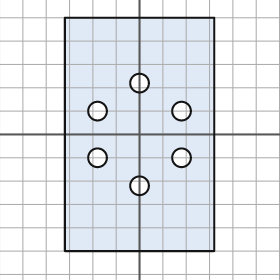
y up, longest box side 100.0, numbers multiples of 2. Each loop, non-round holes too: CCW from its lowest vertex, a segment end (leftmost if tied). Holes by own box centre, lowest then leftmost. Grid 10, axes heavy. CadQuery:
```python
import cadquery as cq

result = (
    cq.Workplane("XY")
    .moveTo(-32.0, -50.0)
    .lineTo(32.0, -50.0)
    .lineTo(32.0, 50.0)
    .lineTo(-32.0, 50.0)
    .close()
    .moveTo(0.0, -22.0)
    .circle(4.0)
    .moveTo(-18.0, -10.0)
    .circle(4.0)
    .moveTo(18.0, -10.0)
    .circle(4.0)
    .moveTo(-18.0, 10.0)
    .circle(4.0)
    .moveTo(18.0, 10.0)
    .circle(4.0)
    .moveTo(0.0, 22.0)
    .circle(4.0)
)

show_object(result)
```